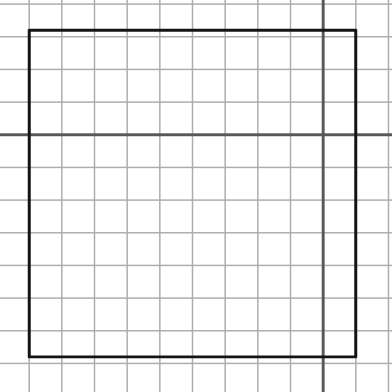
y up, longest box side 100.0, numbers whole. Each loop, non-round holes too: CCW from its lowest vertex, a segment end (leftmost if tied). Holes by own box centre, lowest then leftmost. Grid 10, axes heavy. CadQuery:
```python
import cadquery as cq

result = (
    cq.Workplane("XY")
    .moveTo(-90.0, -68.0)
    .lineTo(10.0, -68.0)
    .lineTo(10.0, 32.0)
    .lineTo(-90.0, 32.0)
    .close()
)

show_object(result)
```